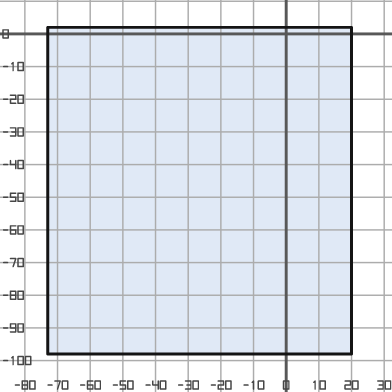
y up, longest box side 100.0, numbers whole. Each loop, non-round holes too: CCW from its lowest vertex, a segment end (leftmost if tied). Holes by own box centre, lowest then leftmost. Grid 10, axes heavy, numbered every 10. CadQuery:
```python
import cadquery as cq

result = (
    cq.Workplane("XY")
    .moveTo(-73.0, -98.0)
    .lineTo(20.0, -98.0)
    .lineTo(20.0, 2.0)
    .lineTo(-73.0, 2.0)
    .close()
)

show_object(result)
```